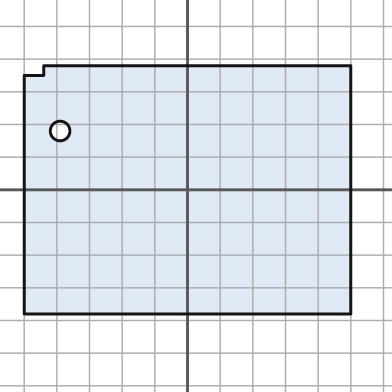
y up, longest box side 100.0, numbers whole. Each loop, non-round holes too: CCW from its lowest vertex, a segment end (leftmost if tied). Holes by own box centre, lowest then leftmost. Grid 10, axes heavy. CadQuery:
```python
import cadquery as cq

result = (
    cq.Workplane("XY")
    .moveTo(-50.0, -38.0)
    .lineTo(50.0, -38.0)
    .lineTo(50.0, 38.0)
    .lineTo(-44.0, 38.0)
    .lineTo(-44.0, 35.0)
    .lineTo(-50.0, 35.0)
    .close()
    .moveTo(-39.0, 18.0)
    .circle(3.0)
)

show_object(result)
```